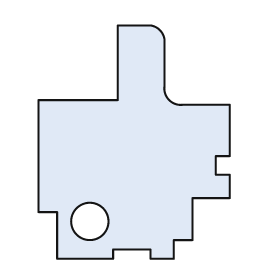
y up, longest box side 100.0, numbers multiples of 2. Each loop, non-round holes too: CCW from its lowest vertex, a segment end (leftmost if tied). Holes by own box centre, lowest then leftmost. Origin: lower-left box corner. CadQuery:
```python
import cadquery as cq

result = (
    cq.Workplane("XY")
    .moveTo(8.0, 0.0)
    .lineTo(32.0, 0.0)
    .lineTo(32.0, 4.0)
    .lineTo(48.0, 4.0)
    .lineTo(48.0, 0.0)
    .lineTo(58.0, 0.0)
    .lineTo(58.0, 8.0)
    .lineTo(66.0, 8.0)
    .lineTo(66.0, 26.0)
    .lineTo(82.0, 26.0)
    .lineTo(82.0, 36.0)
    .lineTo(76.0, 36.0)
    .lineTo(76.0, 44.0)
    .lineTo(82.0, 44.0)
    .lineTo(82.0, 66.0)
    .lineTo(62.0, 66.0)
    .threePointArc((56.0, 68.0), (54.0, 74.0))
    .lineTo(54.0, 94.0)
    .threePointArc((52.0, 98.0), (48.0, 100.0))
    .lineTo(34.0, 100.0)
    .lineTo(34.0, 68.0)
    .lineTo(0.0, 68.0)
    .lineTo(0.0, 20.0)
    .lineTo(8.0, 20.0)
    .close()
    .moveTo(22.0, 16.0)
    .circle(8.0)
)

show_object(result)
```